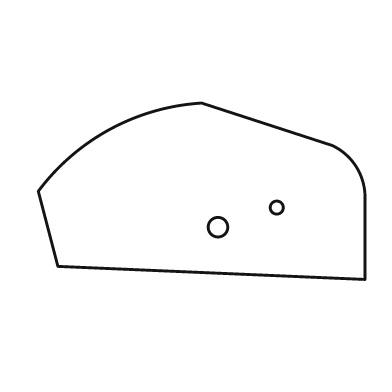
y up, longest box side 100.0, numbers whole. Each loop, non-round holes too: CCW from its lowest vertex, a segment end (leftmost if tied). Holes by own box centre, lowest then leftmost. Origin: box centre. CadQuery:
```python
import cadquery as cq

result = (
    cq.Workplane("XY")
    .moveTo(50.0, -27.0)
    .lineTo(50.0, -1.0)
    .threePointArc((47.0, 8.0), (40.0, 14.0))
    .lineTo(0.0, 27.0)
    .threePointArc((-28.0, 19.0), (-50.0, 0.0))
    .lineTo(-44.0, -23.0)
    .close()
    .moveTo(5.0, -11.0)
    .circle(3.0)
    .moveTo(23.0, -5.0)
    .circle(2.0)
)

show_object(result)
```